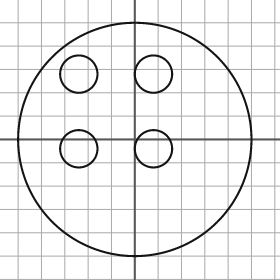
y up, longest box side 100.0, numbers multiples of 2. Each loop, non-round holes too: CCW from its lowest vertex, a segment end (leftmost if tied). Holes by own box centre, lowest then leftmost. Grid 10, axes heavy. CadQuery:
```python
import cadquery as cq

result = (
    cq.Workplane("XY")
    .moveTo(0.0, 0.0)
    .circle(50.0)
    .moveTo(-24.0, -4.0)
    .circle(8.0)
    .moveTo(8.0, -4.0)
    .circle(8.0)
    .moveTo(-24.0, 28.0)
    .circle(8.0)
    .moveTo(8.0, 28.0)
    .circle(8.0)
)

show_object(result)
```